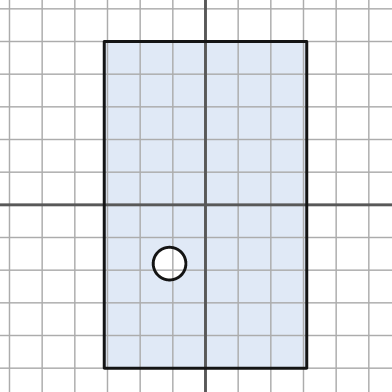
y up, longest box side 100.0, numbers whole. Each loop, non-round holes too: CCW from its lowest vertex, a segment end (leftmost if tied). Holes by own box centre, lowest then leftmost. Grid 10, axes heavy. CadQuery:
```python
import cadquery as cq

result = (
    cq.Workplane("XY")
    .moveTo(-31.0, -50.0)
    .lineTo(31.0, -50.0)
    .lineTo(31.0, 50.0)
    .lineTo(-31.0, 50.0)
    .close()
    .moveTo(-11.0, -18.0)
    .circle(5.0)
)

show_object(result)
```